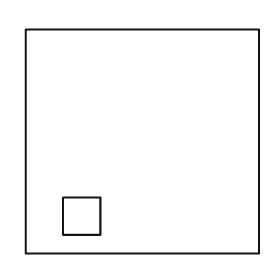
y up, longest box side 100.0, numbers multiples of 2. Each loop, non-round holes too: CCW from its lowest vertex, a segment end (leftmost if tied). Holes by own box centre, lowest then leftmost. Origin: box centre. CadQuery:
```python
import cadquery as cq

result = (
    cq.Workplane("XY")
    .moveTo(-50.0, -48.0)
    .lineTo(50.0, -48.0)
    .lineTo(50.0, 48.0)
    .lineTo(-50.0, 48.0)
    .close()
    .moveTo(-34.0, -40.0)
    .lineTo(-18.0, -40.0)
    .lineTo(-18.0, -24.0)
    .lineTo(-34.0, -24.0)
    .close()
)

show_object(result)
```